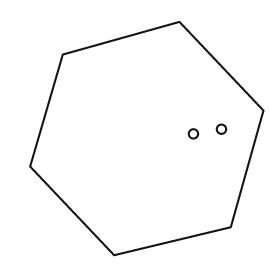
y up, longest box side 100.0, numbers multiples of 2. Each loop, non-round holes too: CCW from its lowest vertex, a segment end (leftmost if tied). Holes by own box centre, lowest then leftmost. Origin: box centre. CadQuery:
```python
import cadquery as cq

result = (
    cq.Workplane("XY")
    .moveTo(-14.0, -50.0)
    .lineTo(36.0, -38.0)
    .lineTo(50.0, 12.0)
    .lineTo(14.0, 50.0)
    .lineTo(-36.0, 36.0)
    .lineTo(-50.0, -12.0)
    .close()
    .moveTo(20.0, 2.0)
    .circle(2.0)
    .moveTo(32.0, 4.0)
    .circle(2.0)
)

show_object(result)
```